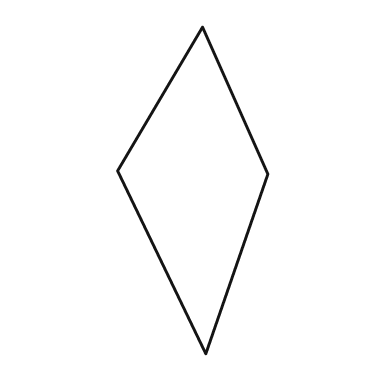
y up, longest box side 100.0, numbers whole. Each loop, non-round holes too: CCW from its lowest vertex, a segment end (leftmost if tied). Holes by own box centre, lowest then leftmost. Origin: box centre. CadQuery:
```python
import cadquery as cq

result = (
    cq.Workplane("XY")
    .moveTo(4.0, -50.0)
    .lineTo(23.0, 5.0)
    .lineTo(3.0, 50.0)
    .lineTo(-23.0, 6.0)
    .close()
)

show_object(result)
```